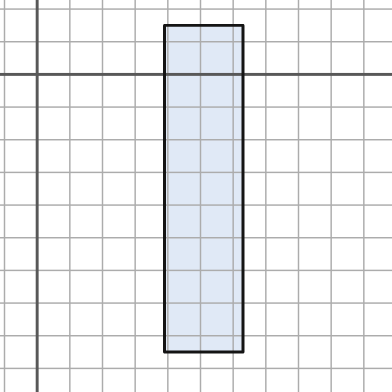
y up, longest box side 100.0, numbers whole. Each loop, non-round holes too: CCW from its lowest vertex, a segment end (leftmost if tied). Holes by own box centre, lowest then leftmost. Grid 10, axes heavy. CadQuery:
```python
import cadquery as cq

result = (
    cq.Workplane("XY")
    .moveTo(39.0, -85.0)
    .lineTo(63.0, -85.0)
    .lineTo(63.0, 15.0)
    .lineTo(39.0, 15.0)
    .close()
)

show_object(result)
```